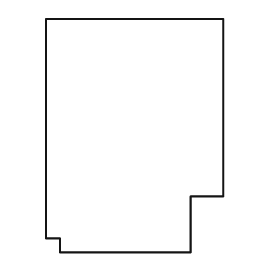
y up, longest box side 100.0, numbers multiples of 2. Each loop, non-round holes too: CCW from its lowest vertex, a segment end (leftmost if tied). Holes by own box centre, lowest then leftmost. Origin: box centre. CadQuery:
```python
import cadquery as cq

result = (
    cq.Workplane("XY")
    .moveTo(-32.0, -50.0)
    .lineTo(24.0, -50.0)
    .lineTo(24.0, -26.0)
    .lineTo(38.0, -26.0)
    .lineTo(38.0, 50.0)
    .lineTo(-38.0, 50.0)
    .lineTo(-38.0, -44.0)
    .lineTo(-32.0, -44.0)
    .close()
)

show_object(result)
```